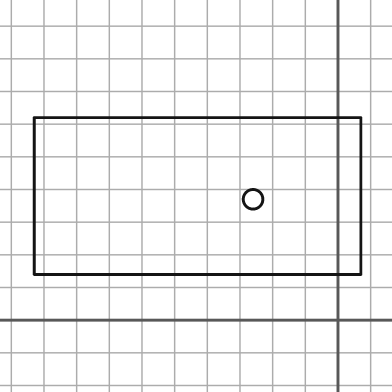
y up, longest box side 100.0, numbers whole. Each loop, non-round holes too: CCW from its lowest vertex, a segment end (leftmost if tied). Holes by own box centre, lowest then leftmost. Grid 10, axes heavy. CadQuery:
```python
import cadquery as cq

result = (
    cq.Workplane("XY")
    .moveTo(-93.0, 14.0)
    .lineTo(7.0, 14.0)
    .lineTo(7.0, 62.0)
    .lineTo(-93.0, 62.0)
    .close()
    .moveTo(-26.0, 37.0)
    .circle(3.0)
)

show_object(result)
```